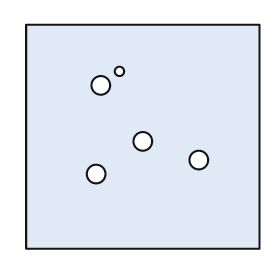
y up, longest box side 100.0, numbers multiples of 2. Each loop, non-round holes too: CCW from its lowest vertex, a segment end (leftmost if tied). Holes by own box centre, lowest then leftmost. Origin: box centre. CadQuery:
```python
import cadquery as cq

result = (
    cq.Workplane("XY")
    .moveTo(-50.0, -48.0)
    .lineTo(50.0, -48.0)
    .lineTo(50.0, 48.0)
    .lineTo(-50.0, 48.0)
    .close()
    .moveTo(-20.0, -16.0)
    .circle(4.0)
    .moveTo(24.0, -10.0)
    .circle(4.0)
    .moveTo(0.0, -2.0)
    .circle(4.0)
    .moveTo(-18.0, 22.0)
    .circle(4.0)
    .moveTo(-10.0, 28.0)
    .circle(2.0)
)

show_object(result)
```